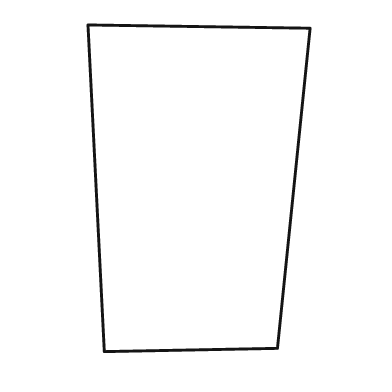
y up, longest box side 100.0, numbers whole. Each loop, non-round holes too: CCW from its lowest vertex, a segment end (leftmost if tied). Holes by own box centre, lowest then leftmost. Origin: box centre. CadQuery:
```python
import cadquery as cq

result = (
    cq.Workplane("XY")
    .moveTo(-29.0, -50.0)
    .lineTo(24.0, -49.0)
    .lineTo(34.0, 49.0)
    .lineTo(-34.0, 50.0)
    .close()
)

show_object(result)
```